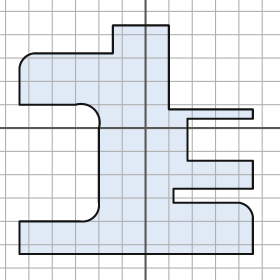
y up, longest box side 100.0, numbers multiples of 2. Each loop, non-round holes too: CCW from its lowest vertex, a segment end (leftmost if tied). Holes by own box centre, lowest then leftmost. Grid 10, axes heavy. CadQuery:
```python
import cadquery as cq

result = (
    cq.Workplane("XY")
    .moveTo(-54.0, -54.0)
    .lineTo(46.0, -54.0)
    .lineTo(46.0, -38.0)
    .threePointArc((44.0, -34.0), (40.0, -32.0))
    .lineTo(12.0, -32.0)
    .lineTo(12.0, -26.0)
    .lineTo(46.0, -26.0)
    .lineTo(46.0, -14.0)
    .lineTo(18.0, -14.0)
    .lineTo(18.0, 4.0)
    .lineTo(46.0, 4.0)
    .lineTo(46.0, 8.0)
    .lineTo(10.0, 8.0)
    .lineTo(10.0, 44.0)
    .lineTo(-14.0, 44.0)
    .lineTo(-14.0, 32.0)
    .lineTo(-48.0, 32.0)
    .threePointArc((-52.0, 30.0), (-54.0, 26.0))
    .lineTo(-54.0, 10.0)
    .lineTo(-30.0, 10.0)
    .threePointArc((-22.0, 8.0), (-20.0, 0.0))
    .lineTo(-20.0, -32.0)
    .threePointArc((-22.0, -38.0), (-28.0, -40.0))
    .lineTo(-54.0, -40.0)
    .close()
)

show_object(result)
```